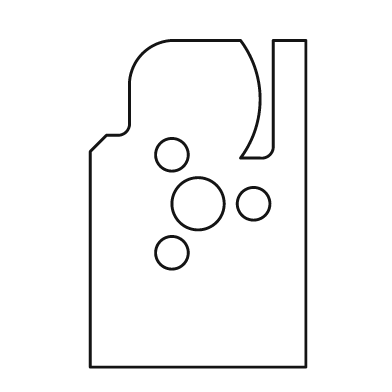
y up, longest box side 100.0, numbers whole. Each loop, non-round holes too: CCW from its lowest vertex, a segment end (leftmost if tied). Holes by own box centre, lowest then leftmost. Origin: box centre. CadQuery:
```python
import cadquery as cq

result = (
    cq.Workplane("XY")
    .moveTo(-33.0, -50.0)
    .lineTo(33.0, -50.0)
    .lineTo(33.0, 50.0)
    .lineTo(23.0, 50.0)
    .lineTo(23.0, 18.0)
    .threePointArc((22.0, 15.0), (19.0, 14.0))
    .lineTo(13.0, 14.0)
    .threePointArc((19.0, 32.0), (13.0, 50.0))
    .lineTo(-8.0, 50.0)
    .threePointArc((-17.0, 46.0), (-21.0, 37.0))
    .lineTo(-21.0, 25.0)
    .threePointArc((-22.0, 22.0), (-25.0, 21.0))
    .lineTo(-28.0, 21.0)
    .lineTo(-33.0, 16.0)
    .close()
    .moveTo(-8.0, -15.0)
    .circle(5.0)
    .moveTo(0.0, 0.0)
    .circle(8.0)
    .moveTo(17.0, 0.0)
    .circle(5.0)
    .moveTo(-8.0, 15.0)
    .circle(5.0)
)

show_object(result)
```